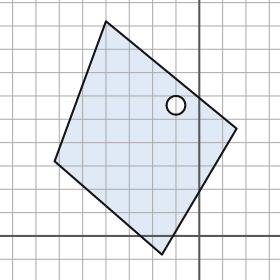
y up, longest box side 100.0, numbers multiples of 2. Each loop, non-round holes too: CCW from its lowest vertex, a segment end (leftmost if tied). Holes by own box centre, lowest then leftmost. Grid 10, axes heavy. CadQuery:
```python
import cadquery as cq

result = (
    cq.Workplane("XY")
    .moveTo(-16.0, -8.0)
    .lineTo(16.0, 46.0)
    .lineTo(-40.0, 92.0)
    .lineTo(-62.0, 32.0)
    .close()
    .moveTo(-10.0, 56.0)
    .circle(4.0)
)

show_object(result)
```